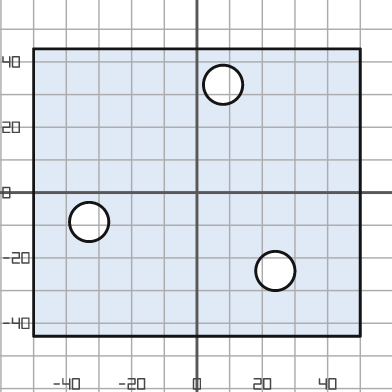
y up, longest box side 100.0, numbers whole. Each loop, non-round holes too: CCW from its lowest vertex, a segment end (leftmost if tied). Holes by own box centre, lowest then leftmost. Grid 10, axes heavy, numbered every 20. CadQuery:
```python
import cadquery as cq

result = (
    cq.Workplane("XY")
    .moveTo(-50.0, -44.0)
    .lineTo(50.0, -44.0)
    .lineTo(50.0, 44.0)
    .lineTo(-50.0, 44.0)
    .close()
    .moveTo(24.0, -24.0)
    .circle(6.0)
    .moveTo(-33.0, -9.0)
    .circle(6.0)
    .moveTo(8.0, 33.0)
    .circle(6.0)
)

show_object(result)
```